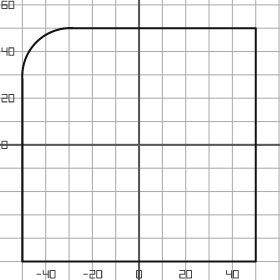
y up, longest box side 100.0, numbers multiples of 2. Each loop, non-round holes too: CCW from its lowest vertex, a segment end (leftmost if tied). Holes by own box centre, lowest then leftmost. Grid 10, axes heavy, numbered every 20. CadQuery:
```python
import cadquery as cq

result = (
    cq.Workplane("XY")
    .moveTo(-50.0, -50.0)
    .lineTo(50.0, -50.0)
    .lineTo(50.0, 50.0)
    .lineTo(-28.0, 50.0)
    .threePointArc((-44.0, 44.0), (-50.0, 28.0))
    .close()
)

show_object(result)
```